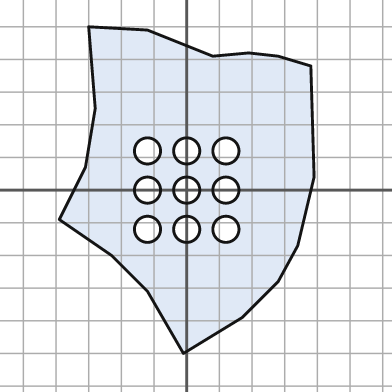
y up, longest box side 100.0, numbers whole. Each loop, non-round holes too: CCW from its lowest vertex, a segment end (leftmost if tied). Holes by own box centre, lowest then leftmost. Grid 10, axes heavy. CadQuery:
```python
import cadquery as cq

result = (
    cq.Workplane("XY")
    .moveTo(-1.0, -50.0)
    .lineTo(17.0, -39.0)
    .lineTo(28.0, -28.0)
    .lineTo(34.0, -17.0)
    .lineTo(39.0, 4.0)
    .lineTo(38.0, 38.0)
    .lineTo(28.0, 41.0)
    .lineTo(19.0, 42.0)
    .lineTo(8.0, 41.0)
    .lineTo(-12.0, 49.0)
    .lineTo(-30.0, 50.0)
    .lineTo(-28.0, 25.0)
    .lineTo(-31.0, 7.0)
    .lineTo(-39.0, -9.0)
    .lineTo(-23.0, -20.0)
    .lineTo(-12.0, -31.0)
    .close()
    .moveTo(-12.0, -12.0)
    .circle(4.0)
    .moveTo(0.0, -12.0)
    .circle(4.0)
    .moveTo(12.0, -12.0)
    .circle(4.0)
    .moveTo(-12.0, 0.0)
    .circle(4.0)
    .moveTo(0.0, 0.0)
    .circle(4.0)
    .moveTo(12.0, 0.0)
    .circle(4.0)
    .moveTo(-12.0, 12.0)
    .circle(4.0)
    .moveTo(0.0, 12.0)
    .circle(4.0)
    .moveTo(12.0, 12.0)
    .circle(4.0)
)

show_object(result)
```